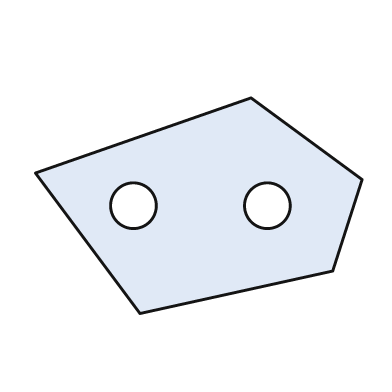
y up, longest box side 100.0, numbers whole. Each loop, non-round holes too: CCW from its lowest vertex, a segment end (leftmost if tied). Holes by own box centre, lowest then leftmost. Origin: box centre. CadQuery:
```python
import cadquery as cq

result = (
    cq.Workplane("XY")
    .moveTo(-18.0, -33.0)
    .lineTo(41.0, -20.0)
    .lineTo(50.0, 8.0)
    .lineTo(16.0, 33.0)
    .lineTo(-50.0, 10.0)
    .close()
    .moveTo(-20.0, 0.0)
    .circle(7.0)
    .moveTo(21.0, 0.0)
    .circle(7.0)
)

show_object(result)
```